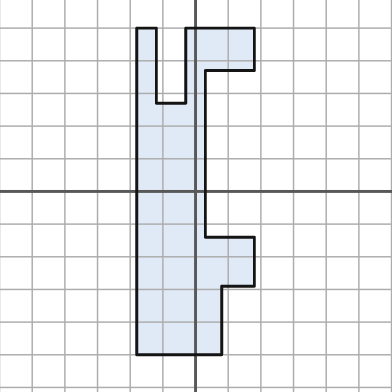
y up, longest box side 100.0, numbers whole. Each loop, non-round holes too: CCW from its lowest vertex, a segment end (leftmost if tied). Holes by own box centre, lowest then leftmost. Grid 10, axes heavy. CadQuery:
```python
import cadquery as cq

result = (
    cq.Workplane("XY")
    .moveTo(-18.0, -50.0)
    .lineTo(8.0, -50.0)
    .lineTo(8.0, -29.0)
    .lineTo(18.0, -29.0)
    .lineTo(18.0, -14.0)
    .lineTo(3.0, -14.0)
    .lineTo(3.0, 37.0)
    .lineTo(18.0, 37.0)
    .lineTo(18.0, 50.0)
    .lineTo(-3.0, 50.0)
    .lineTo(-3.0, 27.0)
    .lineTo(-12.0, 27.0)
    .lineTo(-12.0, 50.0)
    .lineTo(-18.0, 50.0)
    .close()
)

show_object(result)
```